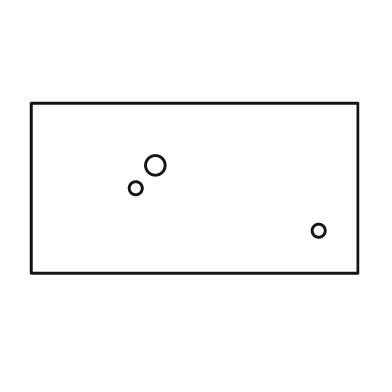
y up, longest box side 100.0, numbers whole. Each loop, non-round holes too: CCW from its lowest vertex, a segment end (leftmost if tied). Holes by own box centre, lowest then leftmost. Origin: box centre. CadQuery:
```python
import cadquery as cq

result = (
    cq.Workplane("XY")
    .moveTo(-50.0, -26.0)
    .lineTo(50.0, -26.0)
    .lineTo(50.0, 26.0)
    .lineTo(-50.0, 26.0)
    .close()
    .moveTo(38.0, -13.0)
    .circle(2.0)
    .moveTo(-18.0, 0.0)
    .circle(2.0)
    .moveTo(-12.0, 7.0)
    .circle(3.0)
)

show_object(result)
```